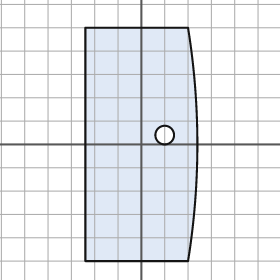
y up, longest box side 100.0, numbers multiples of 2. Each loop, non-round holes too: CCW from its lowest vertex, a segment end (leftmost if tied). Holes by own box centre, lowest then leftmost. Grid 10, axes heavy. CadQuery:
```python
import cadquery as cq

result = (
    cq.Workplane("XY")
    .moveTo(-24.0, -50.0)
    .lineTo(20.0, -50.0)
    .threePointArc((24.0, 0.0), (20.0, 50.0))
    .lineTo(-24.0, 50.0)
    .close()
    .moveTo(10.0, 4.0)
    .circle(4.0)
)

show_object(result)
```